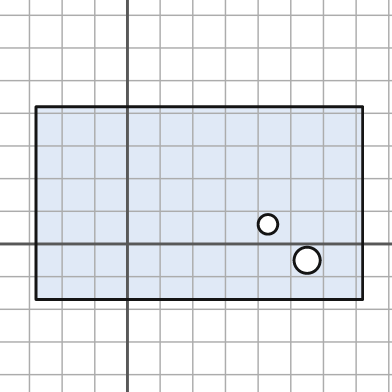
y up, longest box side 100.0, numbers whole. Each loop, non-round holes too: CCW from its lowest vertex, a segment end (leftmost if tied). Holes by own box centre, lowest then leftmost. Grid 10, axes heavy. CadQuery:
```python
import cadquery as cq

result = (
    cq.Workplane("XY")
    .moveTo(-28.0, -17.0)
    .lineTo(72.0, -17.0)
    .lineTo(72.0, 42.0)
    .lineTo(-28.0, 42.0)
    .close()
    .moveTo(55.0, -5.0)
    .circle(4.0)
    .moveTo(43.0, 6.0)
    .circle(3.0)
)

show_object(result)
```